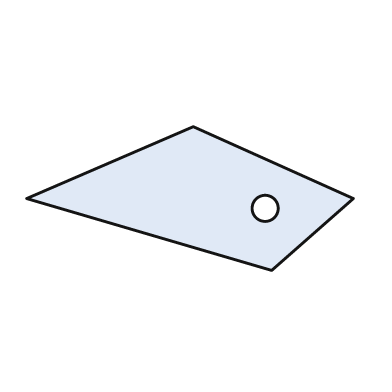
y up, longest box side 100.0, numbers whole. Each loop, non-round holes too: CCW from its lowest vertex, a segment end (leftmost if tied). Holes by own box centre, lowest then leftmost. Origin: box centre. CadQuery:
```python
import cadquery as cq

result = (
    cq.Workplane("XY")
    .moveTo(25.0, -22.0)
    .lineTo(50.0, 0.0)
    .lineTo(1.0, 22.0)
    .lineTo(-50.0, 0.0)
    .close()
    .moveTo(23.0, -3.0)
    .circle(4.0)
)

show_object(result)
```